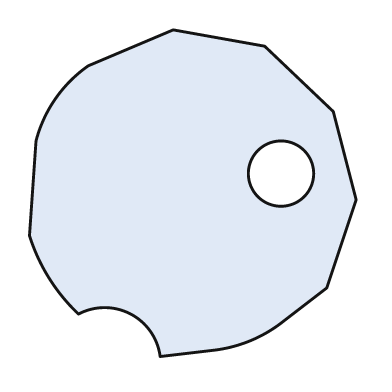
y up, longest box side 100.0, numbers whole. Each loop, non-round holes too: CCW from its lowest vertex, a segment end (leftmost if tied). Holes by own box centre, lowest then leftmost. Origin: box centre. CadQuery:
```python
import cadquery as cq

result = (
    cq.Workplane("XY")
    .moveTo(-10.0, -50.0)
    .lineTo(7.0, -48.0)
    .threePointArc((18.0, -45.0), (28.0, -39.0))
    .lineTo(41.0, -29.0)
    .lineTo(50.0, -2.0)
    .lineTo(43.0, 25.0)
    .lineTo(22.0, 45.0)
    .lineTo(-6.0, 50.0)
    .lineTo(-32.0, 39.0)
    .threePointArc((-42.0, 29.0), (-48.0, 16.0))
    .lineTo(-50.0, -13.0)
    .threePointArc((-44.0, -26.0), (-35.0, -37.0))
    .threePointArc((-19.0, -37.0), (-10.0, -50.0))
    .close()
    .moveTo(27.0, 6.0)
    .circle(10.0)
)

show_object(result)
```